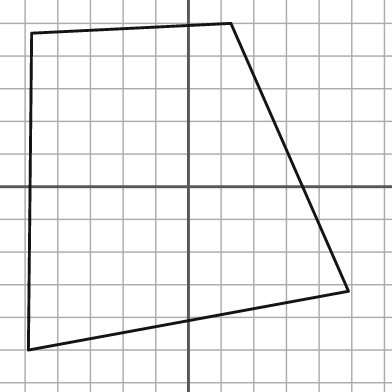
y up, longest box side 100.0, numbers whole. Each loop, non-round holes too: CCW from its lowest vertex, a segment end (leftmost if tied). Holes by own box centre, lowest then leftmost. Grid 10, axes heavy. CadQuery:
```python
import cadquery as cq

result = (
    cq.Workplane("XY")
    .moveTo(-49.0, -50.0)
    .lineTo(49.0, -32.0)
    .lineTo(13.0, 50.0)
    .lineTo(-48.0, 47.0)
    .close()
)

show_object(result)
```